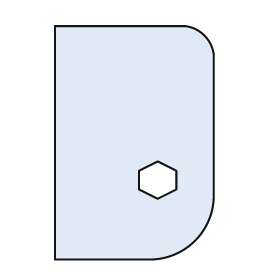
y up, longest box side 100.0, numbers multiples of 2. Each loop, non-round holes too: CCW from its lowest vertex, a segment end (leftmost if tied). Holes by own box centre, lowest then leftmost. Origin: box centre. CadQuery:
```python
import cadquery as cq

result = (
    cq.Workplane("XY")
    .moveTo(-34.0, -50.0)
    .lineTo(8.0, -50.0)
    .threePointArc((26.0, -42.0), (34.0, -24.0))
    .lineTo(34.0, 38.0)
    .threePointArc((30.0, 46.0), (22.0, 50.0))
    .lineTo(-34.0, 50.0)
    .close()
    .moveTo(10.0, -24.0)
    .lineTo(18.0, -20.0)
    .lineTo(18.0, -12.0)
    .lineTo(10.0, -8.0)
    .lineTo(2.0, -12.0)
    .lineTo(2.0, -20.0)
    .close()
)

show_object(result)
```